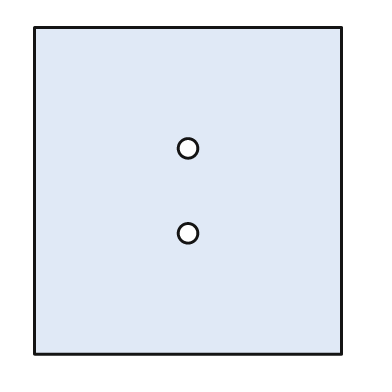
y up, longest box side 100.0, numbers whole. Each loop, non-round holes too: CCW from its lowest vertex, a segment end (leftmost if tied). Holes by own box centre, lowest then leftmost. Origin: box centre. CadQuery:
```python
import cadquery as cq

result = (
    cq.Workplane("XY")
    .moveTo(-47.0, -50.0)
    .lineTo(47.0, -50.0)
    .lineTo(47.0, 50.0)
    .lineTo(-47.0, 50.0)
    .close()
    .moveTo(0.0, -13.0)
    .circle(3.0)
    .moveTo(0.0, 13.0)
    .circle(3.0)
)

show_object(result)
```